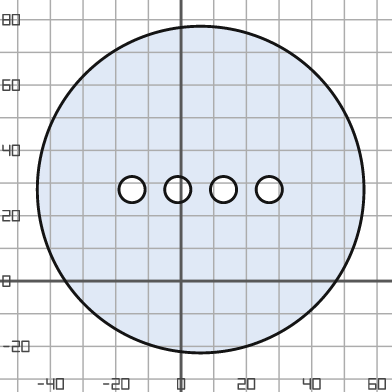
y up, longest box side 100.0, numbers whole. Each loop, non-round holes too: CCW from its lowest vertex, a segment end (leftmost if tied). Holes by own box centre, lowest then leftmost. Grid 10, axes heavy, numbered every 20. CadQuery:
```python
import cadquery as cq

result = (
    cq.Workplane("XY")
    .moveTo(6.0, 28.0)
    .circle(50.0)
    .moveTo(-15.0, 28.0)
    .circle(4.0)
    .moveTo(-1.0, 28.0)
    .circle(4.0)
    .moveTo(13.0, 28.0)
    .circle(4.0)
    .moveTo(27.0, 28.0)
    .circle(4.0)
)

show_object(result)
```